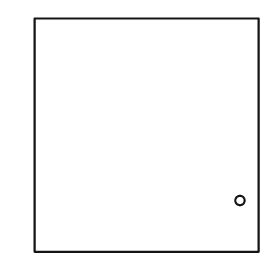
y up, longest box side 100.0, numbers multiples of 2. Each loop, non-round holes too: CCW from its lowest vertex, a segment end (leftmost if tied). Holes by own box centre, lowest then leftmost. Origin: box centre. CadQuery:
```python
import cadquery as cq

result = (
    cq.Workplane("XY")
    .moveTo(-48.0, -50.0)
    .lineTo(48.0, -50.0)
    .lineTo(48.0, 50.0)
    .lineTo(-48.0, 50.0)
    .close()
    .moveTo(40.0, -28.0)
    .circle(2.0)
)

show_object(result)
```